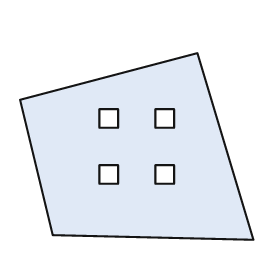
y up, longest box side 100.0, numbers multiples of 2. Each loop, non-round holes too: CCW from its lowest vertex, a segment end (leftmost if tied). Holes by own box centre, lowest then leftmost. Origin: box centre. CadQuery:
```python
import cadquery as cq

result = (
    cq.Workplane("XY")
    .moveTo(50.0, -40.0)
    .lineTo(26.0, 40.0)
    .lineTo(-50.0, 20.0)
    .lineTo(-36.0, -38.0)
    .close()
    .moveTo(-16.0, -16.0)
    .lineTo(-8.0, -16.0)
    .lineTo(-8.0, -8.0)
    .lineTo(-16.0, -8.0)
    .close()
    .moveTo(8.0, -16.0)
    .lineTo(16.0, -16.0)
    .lineTo(16.0, -8.0)
    .lineTo(8.0, -8.0)
    .close()
    .moveTo(-16.0, 8.0)
    .lineTo(-8.0, 8.0)
    .lineTo(-8.0, 16.0)
    .lineTo(-16.0, 16.0)
    .close()
    .moveTo(8.0, 8.0)
    .lineTo(16.0, 8.0)
    .lineTo(16.0, 16.0)
    .lineTo(8.0, 16.0)
    .close()
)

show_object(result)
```